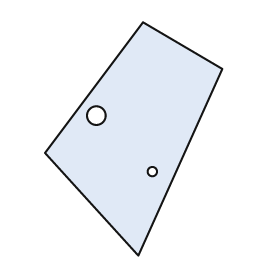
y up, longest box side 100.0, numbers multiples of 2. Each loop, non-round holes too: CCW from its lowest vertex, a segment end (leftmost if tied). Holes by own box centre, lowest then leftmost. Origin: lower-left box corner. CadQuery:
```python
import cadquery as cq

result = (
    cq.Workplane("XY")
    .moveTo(40.0, 0.0)
    .lineTo(76.0, 80.0)
    .lineTo(42.0, 100.0)
    .lineTo(0.0, 44.0)
    .close()
    .moveTo(46.0, 36.0)
    .circle(2.0)
    .moveTo(22.0, 60.0)
    .circle(4.0)
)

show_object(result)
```